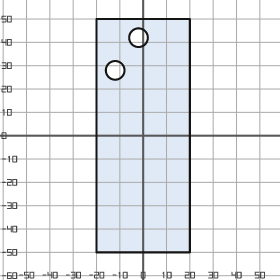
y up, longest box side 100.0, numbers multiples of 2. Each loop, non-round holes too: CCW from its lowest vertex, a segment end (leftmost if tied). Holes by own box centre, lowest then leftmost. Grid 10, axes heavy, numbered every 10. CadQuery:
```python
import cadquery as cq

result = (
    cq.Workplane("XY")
    .moveTo(-20.0, -50.0)
    .lineTo(20.0, -50.0)
    .lineTo(20.0, 50.0)
    .lineTo(-20.0, 50.0)
    .close()
    .moveTo(-12.0, 28.0)
    .circle(4.0)
    .moveTo(-2.0, 42.0)
    .circle(4.0)
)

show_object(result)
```